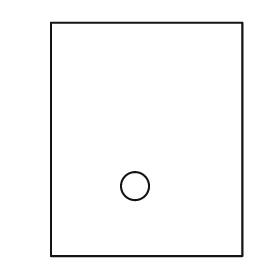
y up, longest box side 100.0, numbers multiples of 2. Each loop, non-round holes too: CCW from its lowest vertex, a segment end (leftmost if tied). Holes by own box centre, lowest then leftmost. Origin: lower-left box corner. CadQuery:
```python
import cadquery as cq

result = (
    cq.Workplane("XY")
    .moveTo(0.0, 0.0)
    .lineTo(82.0, 0.0)
    .lineTo(82.0, 100.0)
    .lineTo(0.0, 100.0)
    .close()
    .moveTo(36.0, 30.0)
    .circle(6.0)
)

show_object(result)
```